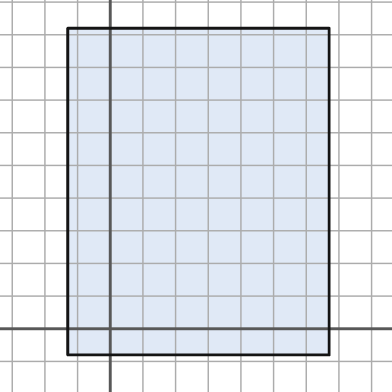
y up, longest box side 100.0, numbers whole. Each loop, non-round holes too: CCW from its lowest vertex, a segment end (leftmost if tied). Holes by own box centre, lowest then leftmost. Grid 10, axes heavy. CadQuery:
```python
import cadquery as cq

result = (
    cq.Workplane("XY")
    .moveTo(-13.0, -8.0)
    .lineTo(67.0, -8.0)
    .lineTo(67.0, 92.0)
    .lineTo(-13.0, 92.0)
    .close()
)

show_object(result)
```